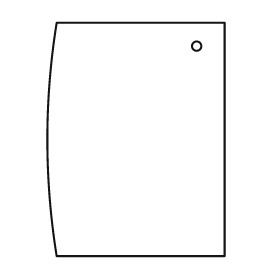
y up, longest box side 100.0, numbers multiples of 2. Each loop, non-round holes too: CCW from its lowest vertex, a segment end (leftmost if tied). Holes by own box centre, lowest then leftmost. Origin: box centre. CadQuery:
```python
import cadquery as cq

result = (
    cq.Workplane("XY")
    .moveTo(-34.0, -50.0)
    .lineTo(38.0, -50.0)
    .lineTo(38.0, 50.0)
    .lineTo(-34.0, 50.0)
    .threePointArc((-38.0, 0.0), (-34.0, -50.0))
    .close()
    .moveTo(26.0, 40.0)
    .circle(2.0)
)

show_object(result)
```